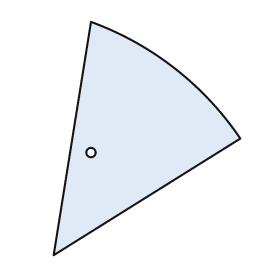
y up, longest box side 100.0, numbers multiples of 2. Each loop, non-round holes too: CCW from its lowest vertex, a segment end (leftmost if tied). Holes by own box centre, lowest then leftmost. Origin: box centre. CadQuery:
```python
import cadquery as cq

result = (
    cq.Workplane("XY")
    .moveTo(-40.0, -50.0)
    .lineTo(40.0, 0.0)
    .threePointArc((12.0, 30.0), (-24.0, 50.0))
    .close()
    .moveTo(-24.0, -6.0)
    .circle(2.0)
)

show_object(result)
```